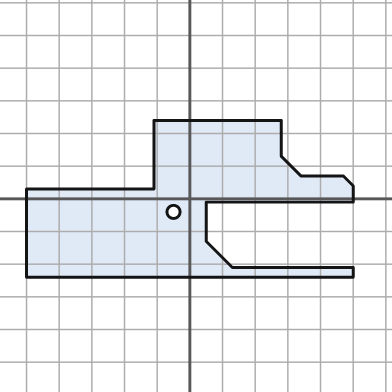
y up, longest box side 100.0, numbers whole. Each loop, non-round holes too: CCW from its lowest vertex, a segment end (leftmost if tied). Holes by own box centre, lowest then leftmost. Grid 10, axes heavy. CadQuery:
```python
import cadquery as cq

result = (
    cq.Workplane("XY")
    .moveTo(-50.0, -24.0)
    .lineTo(50.0, -24.0)
    .lineTo(50.0, -21.0)
    .lineTo(13.0, -21.0)
    .lineTo(5.0, -13.0)
    .lineTo(5.0, -1.0)
    .lineTo(50.0, -1.0)
    .lineTo(50.0, 4.0)
    .lineTo(47.0, 7.0)
    .lineTo(34.0, 7.0)
    .lineTo(28.0, 13.0)
    .lineTo(28.0, 24.0)
    .lineTo(-11.0, 24.0)
    .lineTo(-11.0, 3.0)
    .lineTo(-50.0, 3.0)
    .close()
    .moveTo(-5.0, -4.0)
    .circle(2.0)
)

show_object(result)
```